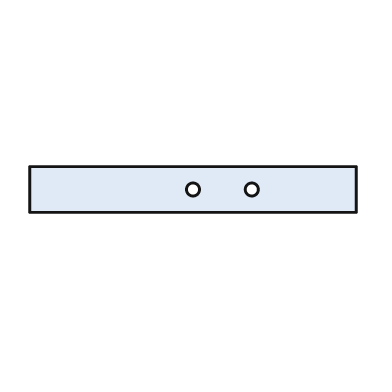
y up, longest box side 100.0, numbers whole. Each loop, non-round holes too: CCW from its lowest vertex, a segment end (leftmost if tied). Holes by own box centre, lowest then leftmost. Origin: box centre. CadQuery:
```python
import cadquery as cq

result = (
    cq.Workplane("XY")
    .moveTo(-50.0, -7.0)
    .lineTo(50.0, -7.0)
    .lineTo(50.0, 7.0)
    .lineTo(-50.0, 7.0)
    .close()
    .moveTo(0.0, 0.0)
    .circle(2.0)
    .moveTo(18.0, 0.0)
    .circle(2.0)
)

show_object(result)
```